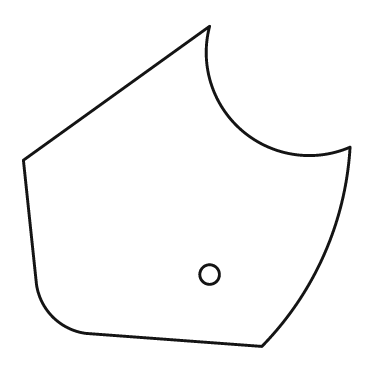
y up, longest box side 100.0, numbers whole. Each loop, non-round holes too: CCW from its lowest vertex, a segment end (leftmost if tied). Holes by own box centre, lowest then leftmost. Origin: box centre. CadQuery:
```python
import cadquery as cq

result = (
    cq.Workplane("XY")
    .moveTo(23.0, -49.0)
    .threePointArc((42.0, -21.0), (50.0, 12.0))
    .threePointArc((17.0, 17.0), (7.0, 49.0))
    .lineTo(-50.0, 8.0)
    .lineTo(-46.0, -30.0)
    .threePointArc((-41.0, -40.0), (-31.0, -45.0))
    .close()
    .moveTo(7.0, -27.0)
    .circle(3.0)
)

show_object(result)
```